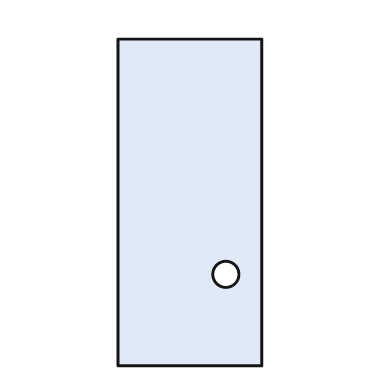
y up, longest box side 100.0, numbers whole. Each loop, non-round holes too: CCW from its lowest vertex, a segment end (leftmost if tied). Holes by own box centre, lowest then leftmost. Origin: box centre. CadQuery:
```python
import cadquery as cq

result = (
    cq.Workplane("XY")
    .moveTo(-22.0, -50.0)
    .lineTo(22.0, -50.0)
    .lineTo(22.0, 50.0)
    .lineTo(-22.0, 50.0)
    .close()
    .moveTo(11.0, -22.0)
    .circle(4.0)
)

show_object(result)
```